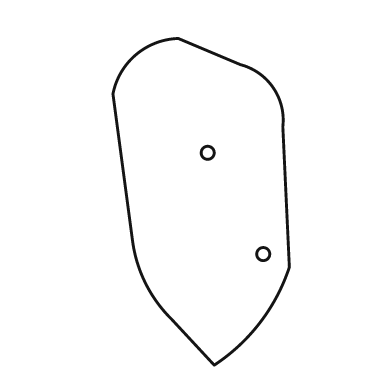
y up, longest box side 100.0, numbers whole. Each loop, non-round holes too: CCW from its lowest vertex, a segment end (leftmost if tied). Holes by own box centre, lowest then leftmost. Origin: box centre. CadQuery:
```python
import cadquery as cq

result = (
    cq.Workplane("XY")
    .moveTo(4.0, -50.0)
    .threePointArc((18.0, -37.0), (27.0, -20.0))
    .lineTo(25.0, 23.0)
    .threePointArc((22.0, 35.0), (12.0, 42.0))
    .lineTo(-7.0, 50.0)
    .threePointArc((-20.0, 45.0), (-27.0, 33.0))
    .lineTo(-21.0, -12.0)
    .threePointArc((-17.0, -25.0), (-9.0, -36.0))
    .close()
    .moveTo(19.0, -16.0)
    .circle(2.0)
    .moveTo(2.0, 15.0)
    .circle(2.0)
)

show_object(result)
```